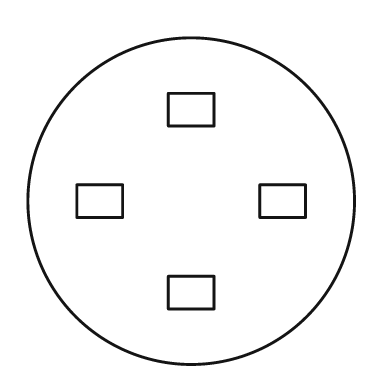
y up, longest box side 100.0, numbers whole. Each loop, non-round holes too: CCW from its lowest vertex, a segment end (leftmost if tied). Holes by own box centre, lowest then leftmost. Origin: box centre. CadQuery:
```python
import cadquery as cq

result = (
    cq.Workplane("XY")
    .moveTo(0.0, 0.0)
    .circle(50.0)
    .moveTo(-7.0, -33.0)
    .lineTo(7.0, -33.0)
    .lineTo(7.0, -23.0)
    .lineTo(-7.0, -23.0)
    .close()
    .moveTo(-35.0, -5.0)
    .lineTo(-21.0, -5.0)
    .lineTo(-21.0, 5.0)
    .lineTo(-35.0, 5.0)
    .close()
    .moveTo(21.0, -5.0)
    .lineTo(35.0, -5.0)
    .lineTo(35.0, 5.0)
    .lineTo(21.0, 5.0)
    .close()
    .moveTo(-7.0, 23.0)
    .lineTo(7.0, 23.0)
    .lineTo(7.0, 33.0)
    .lineTo(-7.0, 33.0)
    .close()
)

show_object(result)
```